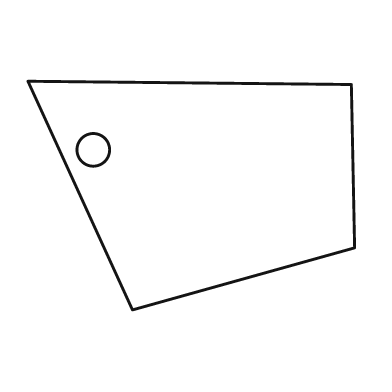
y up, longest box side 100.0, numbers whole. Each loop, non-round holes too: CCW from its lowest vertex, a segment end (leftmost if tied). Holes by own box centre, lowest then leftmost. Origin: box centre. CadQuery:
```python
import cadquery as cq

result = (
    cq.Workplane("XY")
    .moveTo(-18.0, -35.0)
    .lineTo(50.0, -16.0)
    .lineTo(49.0, 34.0)
    .lineTo(-50.0, 35.0)
    .close()
    .moveTo(-30.0, 14.0)
    .circle(5.0)
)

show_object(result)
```